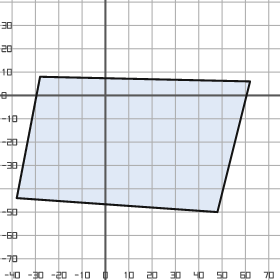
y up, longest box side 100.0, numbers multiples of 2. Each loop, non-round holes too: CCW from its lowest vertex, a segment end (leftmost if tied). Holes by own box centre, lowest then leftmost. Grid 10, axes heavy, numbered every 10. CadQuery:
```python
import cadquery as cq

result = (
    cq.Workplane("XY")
    .moveTo(48.0, -50.0)
    .lineTo(62.0, 6.0)
    .lineTo(-28.0, 8.0)
    .lineTo(-38.0, -44.0)
    .close()
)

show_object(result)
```